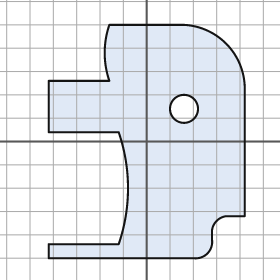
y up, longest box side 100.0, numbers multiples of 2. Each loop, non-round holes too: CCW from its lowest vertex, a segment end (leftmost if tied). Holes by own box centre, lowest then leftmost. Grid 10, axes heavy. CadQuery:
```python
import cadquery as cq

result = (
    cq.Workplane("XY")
    .moveTo(-42.0, -50.0)
    .lineTo(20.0, -50.0)
    .threePointArc((26.0, -48.0), (28.0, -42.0))
    .lineTo(28.0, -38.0)
    .threePointArc((30.0, -34.0), (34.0, -32.0))
    .lineTo(42.0, -32.0)
    .lineTo(42.0, 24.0)
    .threePointArc((34.0, 42.0), (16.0, 50.0))
    .lineTo(-16.0, 50.0)
    .threePointArc((-18.0, 38.0), (-16.0, 26.0))
    .lineTo(-42.0, 26.0)
    .lineTo(-42.0, 4.0)
    .lineTo(-12.0, 4.0)
    .threePointArc((-8.0, -20.0), (-12.0, -44.0))
    .lineTo(-42.0, -44.0)
    .close()
    .moveTo(16.0, 14.0)
    .circle(6.0)
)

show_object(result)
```